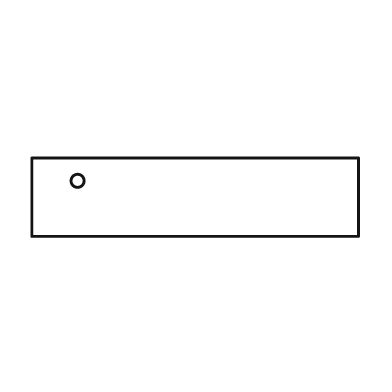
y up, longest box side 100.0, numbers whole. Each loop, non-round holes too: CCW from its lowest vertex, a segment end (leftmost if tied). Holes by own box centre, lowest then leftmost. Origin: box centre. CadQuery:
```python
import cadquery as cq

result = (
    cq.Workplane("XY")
    .moveTo(-50.0, -12.0)
    .lineTo(50.0, -12.0)
    .lineTo(50.0, 12.0)
    .lineTo(-50.0, 12.0)
    .close()
    .moveTo(-36.0, 5.0)
    .circle(2.0)
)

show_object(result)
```